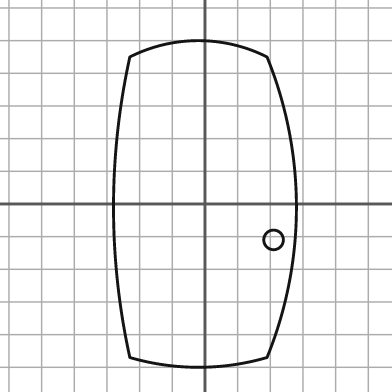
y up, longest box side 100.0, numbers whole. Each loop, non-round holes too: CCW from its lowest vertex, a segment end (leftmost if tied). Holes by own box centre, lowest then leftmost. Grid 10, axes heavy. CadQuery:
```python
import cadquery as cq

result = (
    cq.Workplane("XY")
    .moveTo(-23.0, -47.0)
    .threePointArc((-2.0, -50.0), (19.0, -47.0))
    .threePointArc((28.0, -1.0), (19.0, 45.0))
    .threePointArc((-2.0, 50.0), (-23.0, 45.0))
    .threePointArc((-28.0, -1.0), (-23.0, -47.0))
    .close()
    .moveTo(21.0, -11.0)
    .circle(3.0)
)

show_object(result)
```